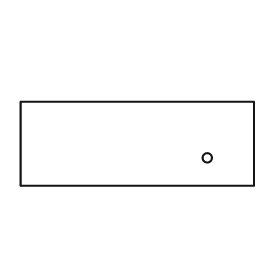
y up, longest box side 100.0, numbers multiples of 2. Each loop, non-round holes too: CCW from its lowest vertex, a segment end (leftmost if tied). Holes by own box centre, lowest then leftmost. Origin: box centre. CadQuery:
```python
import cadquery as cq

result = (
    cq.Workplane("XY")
    .moveTo(-50.0, -18.0)
    .lineTo(50.0, -18.0)
    .lineTo(50.0, 18.0)
    .lineTo(-50.0, 18.0)
    .close()
    .moveTo(30.0, -6.0)
    .circle(2.0)
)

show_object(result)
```